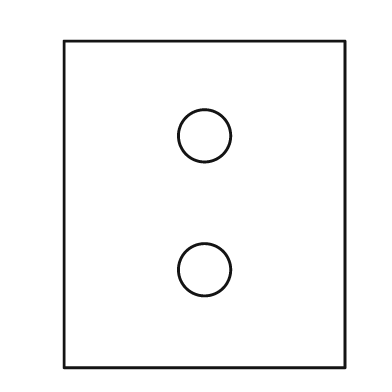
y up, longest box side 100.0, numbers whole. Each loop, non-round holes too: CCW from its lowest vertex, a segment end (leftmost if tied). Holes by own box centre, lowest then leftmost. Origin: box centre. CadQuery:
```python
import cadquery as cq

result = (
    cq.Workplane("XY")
    .moveTo(-43.0, -50.0)
    .lineTo(43.0, -50.0)
    .lineTo(43.0, 50.0)
    .lineTo(-43.0, 50.0)
    .close()
    .moveTo(0.0, -20.0)
    .circle(8.0)
    .moveTo(0.0, 21.0)
    .circle(8.0)
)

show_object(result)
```